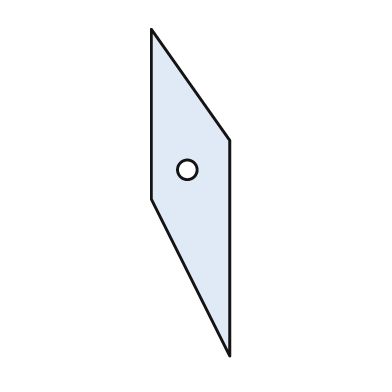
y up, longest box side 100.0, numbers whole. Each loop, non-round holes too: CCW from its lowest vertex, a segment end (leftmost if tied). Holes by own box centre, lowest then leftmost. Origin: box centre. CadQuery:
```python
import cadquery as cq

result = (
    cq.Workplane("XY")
    .moveTo(12.0, -50.0)
    .lineTo(12.0, 16.0)
    .lineTo(-12.0, 50.0)
    .lineTo(-12.0, -2.0)
    .close()
    .moveTo(-1.0, 7.0)
    .circle(3.0)
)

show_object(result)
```